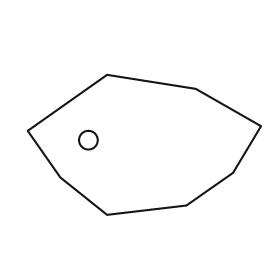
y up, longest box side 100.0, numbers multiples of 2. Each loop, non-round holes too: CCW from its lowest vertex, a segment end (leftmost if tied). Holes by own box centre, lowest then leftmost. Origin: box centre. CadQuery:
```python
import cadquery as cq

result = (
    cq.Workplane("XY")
    .moveTo(-16.0, -30.0)
    .lineTo(18.0, -26.0)
    .lineTo(38.0, -12.0)
    .lineTo(50.0, 8.0)
    .lineTo(22.0, 24.0)
    .lineTo(-16.0, 30.0)
    .lineTo(-50.0, 6.0)
    .lineTo(-36.0, -14.0)
    .close()
    .moveTo(-24.0, 2.0)
    .circle(4.0)
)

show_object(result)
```